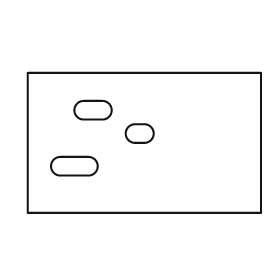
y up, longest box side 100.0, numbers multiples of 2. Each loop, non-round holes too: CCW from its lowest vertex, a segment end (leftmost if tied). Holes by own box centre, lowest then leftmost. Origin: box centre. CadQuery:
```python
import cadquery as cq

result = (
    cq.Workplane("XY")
    .moveTo(-50.0, -30.0)
    .lineTo(50.0, -30.0)
    .lineTo(50.0, 30.0)
    .lineTo(-50.0, 30.0)
    .close()
    .moveTo(-36.0, -14.0)
    .lineTo(-24.0, -14.0)
    .threePointArc((-20.0, -10.0), (-24.0, -6.0))
    .lineTo(-36.0, -6.0)
    .threePointArc((-40.0, -10.0), (-36.0, -14.0))
    .close()
    .moveTo(-4.0, 0.0)
    .lineTo(0.0, 0.0)
    .threePointArc((4.0, 4.0), (0.0, 8.0))
    .lineTo(-4.0, 8.0)
    .threePointArc((-8.0, 4.0), (-4.0, 0.0))
    .close()
    .moveTo(-26.0, 10.0)
    .lineTo(-18.0, 10.0)
    .threePointArc((-14.0, 14.0), (-18.0, 18.0))
    .lineTo(-26.0, 18.0)
    .threePointArc((-30.0, 14.0), (-26.0, 10.0))
    .close()
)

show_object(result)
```